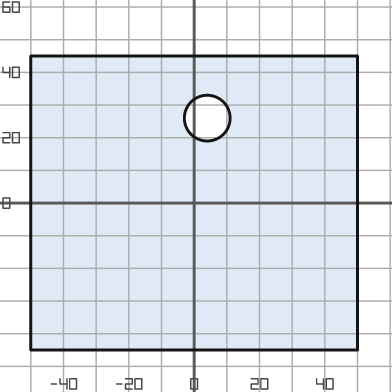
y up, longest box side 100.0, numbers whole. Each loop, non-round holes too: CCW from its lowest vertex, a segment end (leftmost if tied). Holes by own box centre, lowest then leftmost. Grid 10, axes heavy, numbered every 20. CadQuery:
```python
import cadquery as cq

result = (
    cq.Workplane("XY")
    .moveTo(-50.0, -45.0)
    .lineTo(50.0, -45.0)
    .lineTo(50.0, 45.0)
    .lineTo(-50.0, 45.0)
    .close()
    .moveTo(4.0, 26.0)
    .circle(7.0)
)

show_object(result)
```